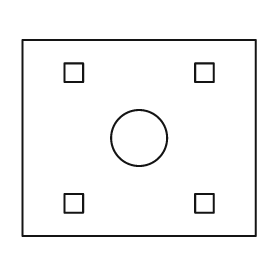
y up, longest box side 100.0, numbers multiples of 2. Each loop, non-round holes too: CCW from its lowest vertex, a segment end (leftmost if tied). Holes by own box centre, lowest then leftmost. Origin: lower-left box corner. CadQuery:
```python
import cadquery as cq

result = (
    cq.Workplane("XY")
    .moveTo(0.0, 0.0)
    .lineTo(100.0, 0.0)
    .lineTo(100.0, 84.0)
    .lineTo(0.0, 84.0)
    .close()
    .moveTo(18.0, 10.0)
    .lineTo(26.0, 10.0)
    .lineTo(26.0, 18.0)
    .lineTo(18.0, 18.0)
    .close()
    .moveTo(74.0, 10.0)
    .lineTo(82.0, 10.0)
    .lineTo(82.0, 18.0)
    .lineTo(74.0, 18.0)
    .close()
    .moveTo(50.0, 42.0)
    .circle(12.0)
    .moveTo(18.0, 66.0)
    .lineTo(26.0, 66.0)
    .lineTo(26.0, 74.0)
    .lineTo(18.0, 74.0)
    .close()
    .moveTo(74.0, 66.0)
    .lineTo(82.0, 66.0)
    .lineTo(82.0, 74.0)
    .lineTo(74.0, 74.0)
    .close()
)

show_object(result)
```